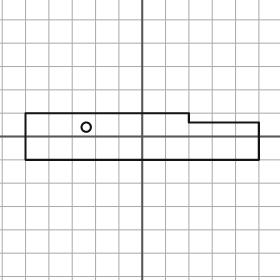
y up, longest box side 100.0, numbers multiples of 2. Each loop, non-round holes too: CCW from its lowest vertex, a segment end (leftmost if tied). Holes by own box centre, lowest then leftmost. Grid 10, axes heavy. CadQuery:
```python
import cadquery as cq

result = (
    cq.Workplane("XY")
    .moveTo(-50.0, -10.0)
    .lineTo(50.0, -10.0)
    .lineTo(50.0, 6.0)
    .lineTo(20.0, 6.0)
    .lineTo(20.0, 10.0)
    .lineTo(-50.0, 10.0)
    .close()
    .moveTo(-24.0, 4.0)
    .circle(2.0)
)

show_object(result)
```